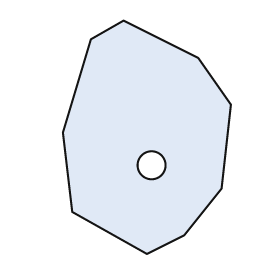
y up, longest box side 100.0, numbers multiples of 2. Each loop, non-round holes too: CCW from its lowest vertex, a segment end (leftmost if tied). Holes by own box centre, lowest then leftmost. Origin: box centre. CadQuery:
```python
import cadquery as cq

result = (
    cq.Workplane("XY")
    .moveTo(0.0, -50.0)
    .lineTo(16.0, -42.0)
    .lineTo(32.0, -22.0)
    .lineTo(36.0, 14.0)
    .lineTo(22.0, 34.0)
    .lineTo(-10.0, 50.0)
    .lineTo(-24.0, 42.0)
    .lineTo(-36.0, 2.0)
    .lineTo(-32.0, -32.0)
    .close()
    .moveTo(2.0, -12.0)
    .circle(6.0)
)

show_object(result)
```